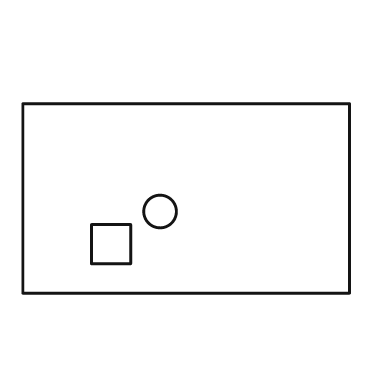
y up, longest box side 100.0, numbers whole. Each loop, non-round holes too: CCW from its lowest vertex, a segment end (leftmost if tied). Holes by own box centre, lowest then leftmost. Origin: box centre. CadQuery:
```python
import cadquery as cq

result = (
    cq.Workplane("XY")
    .moveTo(-50.0, -29.0)
    .lineTo(50.0, -29.0)
    .lineTo(50.0, 29.0)
    .lineTo(-50.0, 29.0)
    .close()
    .moveTo(-29.0, -20.0)
    .lineTo(-17.0, -20.0)
    .lineTo(-17.0, -8.0)
    .lineTo(-29.0, -8.0)
    .close()
    .moveTo(-8.0, -4.0)
    .circle(5.0)
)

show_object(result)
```